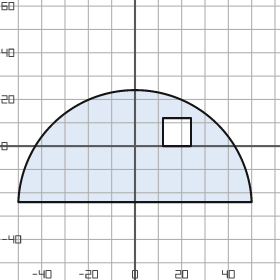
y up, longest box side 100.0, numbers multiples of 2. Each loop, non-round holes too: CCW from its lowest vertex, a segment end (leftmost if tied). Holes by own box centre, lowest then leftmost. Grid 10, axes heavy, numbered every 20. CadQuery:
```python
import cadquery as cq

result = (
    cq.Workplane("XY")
    .moveTo(-50.0, -24.0)
    .lineTo(50.0, -24.0)
    .threePointArc((0.0, 24.0), (-50.0, -24.0))
    .close()
    .moveTo(12.0, 0.0)
    .lineTo(24.0, 0.0)
    .lineTo(24.0, 12.0)
    .lineTo(12.0, 12.0)
    .close()
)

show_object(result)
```